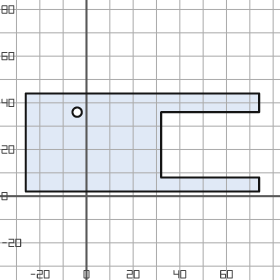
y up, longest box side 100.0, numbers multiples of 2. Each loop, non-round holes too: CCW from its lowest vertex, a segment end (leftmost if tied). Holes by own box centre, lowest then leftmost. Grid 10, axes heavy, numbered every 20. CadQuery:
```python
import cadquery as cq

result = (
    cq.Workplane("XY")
    .moveTo(-26.0, 2.0)
    .lineTo(74.0, 2.0)
    .lineTo(74.0, 8.0)
    .lineTo(32.0, 8.0)
    .lineTo(32.0, 36.0)
    .lineTo(74.0, 36.0)
    .lineTo(74.0, 44.0)
    .lineTo(-26.0, 44.0)
    .close()
    .moveTo(-4.0, 36.0)
    .circle(2.0)
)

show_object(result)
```